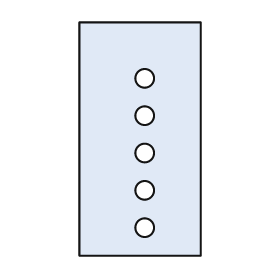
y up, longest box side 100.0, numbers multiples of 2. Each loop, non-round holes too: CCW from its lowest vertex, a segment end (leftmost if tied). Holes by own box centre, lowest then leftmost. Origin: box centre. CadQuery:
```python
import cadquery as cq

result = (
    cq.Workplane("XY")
    .moveTo(-26.0, -50.0)
    .lineTo(26.0, -50.0)
    .lineTo(26.0, 50.0)
    .lineTo(-26.0, 50.0)
    .close()
    .moveTo(2.0, -38.0)
    .circle(4.0)
    .moveTo(2.0, -22.0)
    .circle(4.0)
    .moveTo(2.0, -6.0)
    .circle(4.0)
    .moveTo(2.0, 10.0)
    .circle(4.0)
    .moveTo(2.0, 26.0)
    .circle(4.0)
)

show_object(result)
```